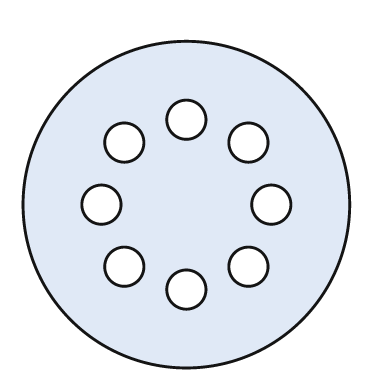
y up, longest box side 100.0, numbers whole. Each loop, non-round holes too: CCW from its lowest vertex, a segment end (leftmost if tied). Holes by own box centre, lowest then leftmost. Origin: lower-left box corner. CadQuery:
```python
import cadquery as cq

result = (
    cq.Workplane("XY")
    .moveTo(50.0, 50.0)
    .circle(50.0)
    .moveTo(50.0, 24.0)
    .circle(6.0)
    .moveTo(31.0, 31.0)
    .circle(6.0)
    .moveTo(69.0, 31.0)
    .circle(6.0)
    .moveTo(24.0, 50.0)
    .circle(6.0)
    .moveTo(76.0, 50.0)
    .circle(6.0)
    .moveTo(31.0, 69.0)
    .circle(6.0)
    .moveTo(69.0, 69.0)
    .circle(6.0)
    .moveTo(50.0, 76.0)
    .circle(6.0)
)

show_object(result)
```